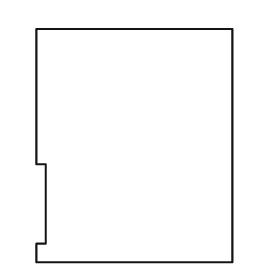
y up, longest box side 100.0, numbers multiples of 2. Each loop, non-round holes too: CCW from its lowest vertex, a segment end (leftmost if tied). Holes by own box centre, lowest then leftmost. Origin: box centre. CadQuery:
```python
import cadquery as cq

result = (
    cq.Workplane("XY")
    .moveTo(-42.0, -50.0)
    .lineTo(42.0, -50.0)
    .lineTo(42.0, 50.0)
    .lineTo(-42.0, 50.0)
    .lineTo(-42.0, -8.0)
    .lineTo(-38.0, -8.0)
    .lineTo(-38.0, -42.0)
    .lineTo(-42.0, -42.0)
    .close()
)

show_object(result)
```